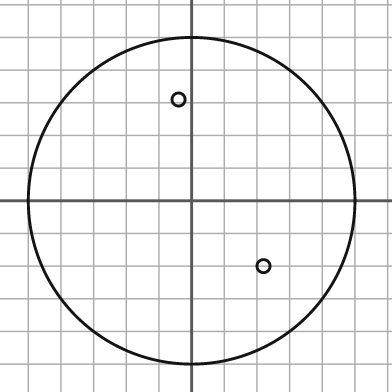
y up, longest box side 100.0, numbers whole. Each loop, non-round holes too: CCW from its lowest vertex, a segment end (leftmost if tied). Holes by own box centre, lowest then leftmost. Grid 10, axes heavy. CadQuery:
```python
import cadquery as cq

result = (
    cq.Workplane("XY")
    .moveTo(0.0, 0.0)
    .circle(50.0)
    .moveTo(22.0, -20.0)
    .circle(2.0)
    .moveTo(-4.0, 31.0)
    .circle(2.0)
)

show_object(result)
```